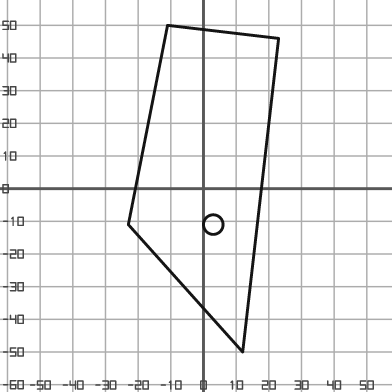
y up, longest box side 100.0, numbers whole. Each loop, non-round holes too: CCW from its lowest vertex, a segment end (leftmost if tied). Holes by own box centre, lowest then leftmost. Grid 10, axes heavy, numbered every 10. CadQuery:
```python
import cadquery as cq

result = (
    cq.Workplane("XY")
    .moveTo(12.0, -50.0)
    .lineTo(23.0, 46.0)
    .lineTo(-11.0, 50.0)
    .lineTo(-23.0, -11.0)
    .close()
    .moveTo(3.0, -11.0)
    .circle(3.0)
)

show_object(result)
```